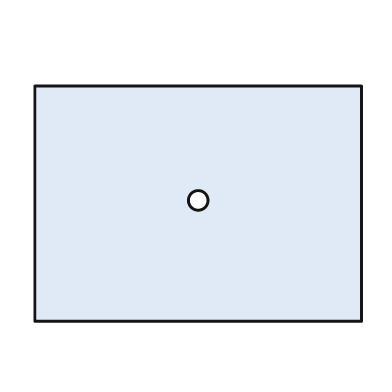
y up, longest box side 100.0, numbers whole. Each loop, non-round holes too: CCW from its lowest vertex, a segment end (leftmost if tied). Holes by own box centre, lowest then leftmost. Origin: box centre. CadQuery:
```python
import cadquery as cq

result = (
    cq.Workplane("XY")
    .moveTo(-50.0, -36.0)
    .lineTo(50.0, -36.0)
    .lineTo(50.0, 36.0)
    .lineTo(-50.0, 36.0)
    .close()
    .moveTo(0.0, 1.0)
    .circle(3.0)
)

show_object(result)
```